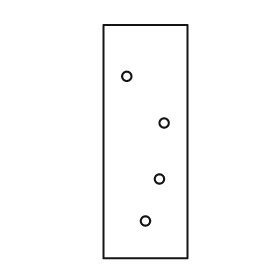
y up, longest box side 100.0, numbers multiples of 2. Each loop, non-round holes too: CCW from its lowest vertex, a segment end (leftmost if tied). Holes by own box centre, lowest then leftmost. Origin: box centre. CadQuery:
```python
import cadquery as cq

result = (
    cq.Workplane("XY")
    .moveTo(-18.0, -50.0)
    .lineTo(18.0, -50.0)
    .lineTo(18.0, 50.0)
    .lineTo(-18.0, 50.0)
    .close()
    .moveTo(0.0, -34.0)
    .circle(2.0)
    .moveTo(6.0, -16.0)
    .circle(2.0)
    .moveTo(8.0, 8.0)
    .circle(2.0)
    .moveTo(-8.0, 28.0)
    .circle(2.0)
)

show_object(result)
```